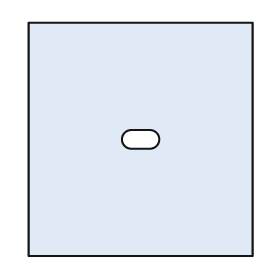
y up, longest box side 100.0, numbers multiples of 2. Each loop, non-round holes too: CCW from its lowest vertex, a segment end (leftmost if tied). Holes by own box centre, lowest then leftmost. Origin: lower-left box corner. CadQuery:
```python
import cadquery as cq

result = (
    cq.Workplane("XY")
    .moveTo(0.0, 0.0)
    .lineTo(96.0, 0.0)
    .lineTo(96.0, 100.0)
    .lineTo(0.0, 100.0)
    .close()
    .moveTo(44.0, 46.0)
    .lineTo(52.0, 46.0)
    .threePointArc((56.0, 50.0), (52.0, 54.0))
    .lineTo(44.0, 54.0)
    .threePointArc((40.0, 50.0), (44.0, 46.0))
    .close()
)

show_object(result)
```